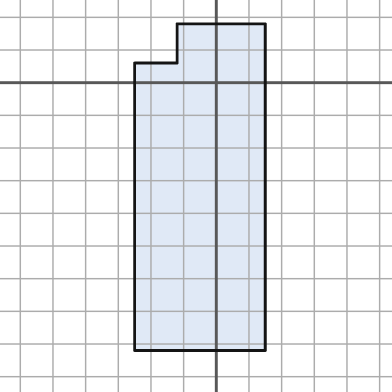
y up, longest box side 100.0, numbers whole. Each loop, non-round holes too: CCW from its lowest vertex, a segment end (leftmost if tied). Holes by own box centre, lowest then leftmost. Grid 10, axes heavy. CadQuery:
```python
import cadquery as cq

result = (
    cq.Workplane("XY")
    .moveTo(-25.0, -82.0)
    .lineTo(15.0, -82.0)
    .lineTo(15.0, 18.0)
    .lineTo(-12.0, 18.0)
    .lineTo(-12.0, 6.0)
    .lineTo(-25.0, 6.0)
    .close()
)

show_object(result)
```